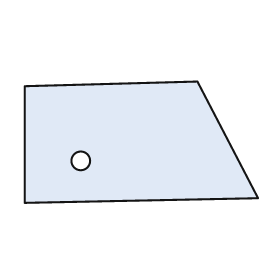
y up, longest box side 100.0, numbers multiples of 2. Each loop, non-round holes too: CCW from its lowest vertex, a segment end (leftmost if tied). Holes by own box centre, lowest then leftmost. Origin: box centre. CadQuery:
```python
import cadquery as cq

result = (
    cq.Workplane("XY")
    .moveTo(-50.0, -26.0)
    .lineTo(50.0, -24.0)
    .lineTo(24.0, 26.0)
    .lineTo(-50.0, 24.0)
    .close()
    .moveTo(-26.0, -8.0)
    .circle(4.0)
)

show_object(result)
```